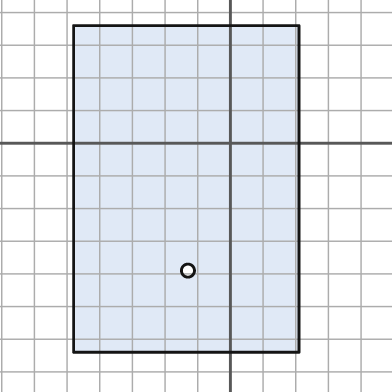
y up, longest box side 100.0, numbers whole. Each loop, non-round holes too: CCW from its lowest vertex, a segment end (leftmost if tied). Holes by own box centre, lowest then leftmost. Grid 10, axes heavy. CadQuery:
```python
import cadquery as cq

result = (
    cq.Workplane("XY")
    .moveTo(-48.0, -64.0)
    .lineTo(21.0, -64.0)
    .lineTo(21.0, 36.0)
    .lineTo(-48.0, 36.0)
    .close()
    .moveTo(-13.0, -39.0)
    .circle(2.0)
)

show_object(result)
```